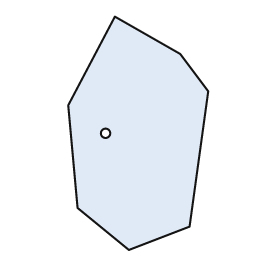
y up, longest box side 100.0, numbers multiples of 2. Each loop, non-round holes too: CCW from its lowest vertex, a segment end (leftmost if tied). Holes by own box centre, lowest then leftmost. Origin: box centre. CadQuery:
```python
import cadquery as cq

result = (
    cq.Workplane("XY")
    .moveTo(-4.0, -50.0)
    .lineTo(22.0, -40.0)
    .lineTo(30.0, 18.0)
    .lineTo(18.0, 34.0)
    .lineTo(-10.0, 50.0)
    .lineTo(-30.0, 12.0)
    .lineTo(-26.0, -32.0)
    .close()
    .moveTo(-14.0, 0.0)
    .circle(2.0)
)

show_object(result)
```